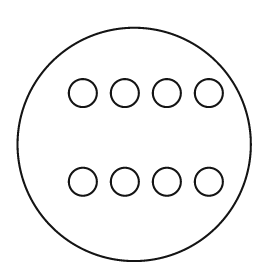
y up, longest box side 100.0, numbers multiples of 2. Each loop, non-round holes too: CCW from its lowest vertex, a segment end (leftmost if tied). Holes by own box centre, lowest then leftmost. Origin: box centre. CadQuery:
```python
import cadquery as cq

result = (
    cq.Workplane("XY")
    .moveTo(0.0, 0.0)
    .circle(50.0)
    .moveTo(-22.0, -16.0)
    .circle(6.0)
    .moveTo(-4.0, -16.0)
    .circle(6.0)
    .moveTo(14.0, -16.0)
    .circle(6.0)
    .moveTo(32.0, -16.0)
    .circle(6.0)
    .moveTo(-22.0, 22.0)
    .circle(6.0)
    .moveTo(-4.0, 22.0)
    .circle(6.0)
    .moveTo(14.0, 22.0)
    .circle(6.0)
    .moveTo(32.0, 22.0)
    .circle(6.0)
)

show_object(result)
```